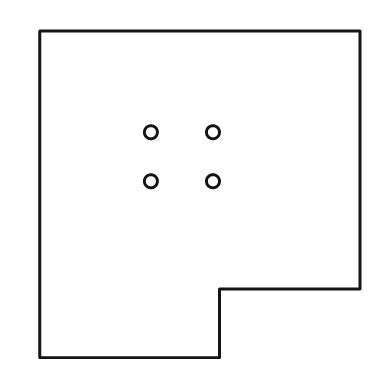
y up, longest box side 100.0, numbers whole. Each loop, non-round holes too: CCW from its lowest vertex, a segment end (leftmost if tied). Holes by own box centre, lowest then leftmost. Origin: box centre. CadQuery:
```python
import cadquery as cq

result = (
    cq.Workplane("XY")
    .moveTo(-49.0, -50.0)
    .lineTo(6.0, -50.0)
    .lineTo(6.0, -29.0)
    .lineTo(49.0, -29.0)
    .lineTo(49.0, 50.0)
    .lineTo(-49.0, 50.0)
    .close()
    .moveTo(-15.0, 4.0)
    .circle(2.0)
    .moveTo(4.0, 4.0)
    .circle(2.0)
    .moveTo(-15.0, 19.0)
    .circle(2.0)
    .moveTo(4.0, 19.0)
    .circle(2.0)
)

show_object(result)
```